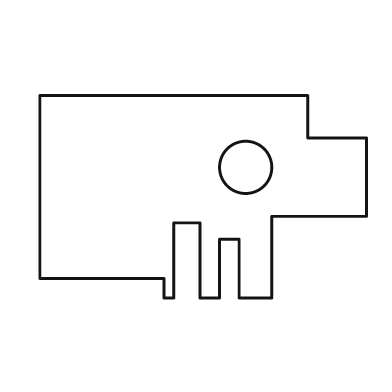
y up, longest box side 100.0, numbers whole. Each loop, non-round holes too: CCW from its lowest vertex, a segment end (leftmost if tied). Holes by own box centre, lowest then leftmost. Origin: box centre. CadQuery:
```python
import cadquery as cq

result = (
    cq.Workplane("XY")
    .moveTo(-12.0, -31.0)
    .lineTo(-9.0, -31.0)
    .lineTo(-9.0, -8.0)
    .lineTo(-1.0, -8.0)
    .lineTo(-1.0, -31.0)
    .lineTo(5.0, -31.0)
    .lineTo(5.0, -13.0)
    .lineTo(11.0, -13.0)
    .lineTo(11.0, -31.0)
    .lineTo(21.0, -31.0)
    .lineTo(21.0, -6.0)
    .lineTo(50.0, -6.0)
    .lineTo(50.0, 18.0)
    .lineTo(32.0, 18.0)
    .lineTo(32.0, 31.0)
    .lineTo(-50.0, 31.0)
    .lineTo(-50.0, -25.0)
    .lineTo(-12.0, -25.0)
    .close()
    .moveTo(13.0, 9.0)
    .circle(8.0)
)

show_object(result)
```